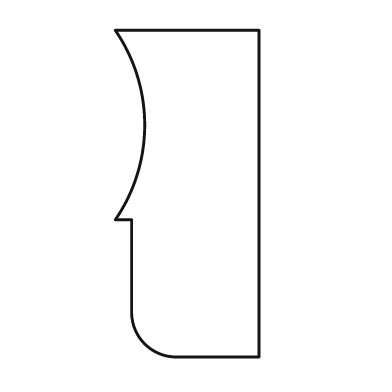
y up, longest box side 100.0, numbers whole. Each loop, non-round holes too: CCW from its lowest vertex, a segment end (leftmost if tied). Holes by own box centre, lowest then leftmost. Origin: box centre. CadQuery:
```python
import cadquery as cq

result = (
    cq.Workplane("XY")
    .moveTo(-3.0, -50.0)
    .lineTo(22.0, -50.0)
    .lineTo(22.0, 50.0)
    .lineTo(-22.0, 50.0)
    .threePointArc((-13.0, 21.0), (-22.0, -8.0))
    .lineTo(-17.0, -8.0)
    .lineTo(-17.0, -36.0)
    .threePointArc((-13.0, -46.0), (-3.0, -50.0))
    .close()
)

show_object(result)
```